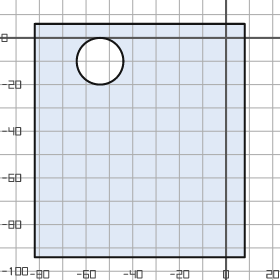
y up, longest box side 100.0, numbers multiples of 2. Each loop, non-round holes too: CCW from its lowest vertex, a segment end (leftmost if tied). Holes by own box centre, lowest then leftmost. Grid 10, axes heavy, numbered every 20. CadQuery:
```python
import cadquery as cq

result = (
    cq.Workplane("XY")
    .moveTo(-82.0, -94.0)
    .lineTo(8.0, -94.0)
    .lineTo(8.0, 6.0)
    .lineTo(-82.0, 6.0)
    .close()
    .moveTo(-54.0, -10.0)
    .circle(10.0)
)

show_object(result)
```